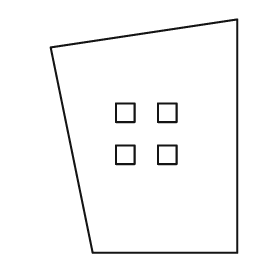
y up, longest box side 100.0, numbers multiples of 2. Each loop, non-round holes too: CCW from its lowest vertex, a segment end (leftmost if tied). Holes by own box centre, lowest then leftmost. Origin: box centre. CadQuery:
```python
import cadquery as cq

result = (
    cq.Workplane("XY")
    .moveTo(-22.0, -50.0)
    .lineTo(40.0, -50.0)
    .lineTo(40.0, 50.0)
    .lineTo(-40.0, 38.0)
    .close()
    .moveTo(-12.0, -12.0)
    .lineTo(-4.0, -12.0)
    .lineTo(-4.0, -4.0)
    .lineTo(-12.0, -4.0)
    .close()
    .moveTo(6.0, -12.0)
    .lineTo(14.0, -12.0)
    .lineTo(14.0, -4.0)
    .lineTo(6.0, -4.0)
    .close()
    .moveTo(-12.0, 6.0)
    .lineTo(-4.0, 6.0)
    .lineTo(-4.0, 14.0)
    .lineTo(-12.0, 14.0)
    .close()
    .moveTo(6.0, 6.0)
    .lineTo(14.0, 6.0)
    .lineTo(14.0, 14.0)
    .lineTo(6.0, 14.0)
    .close()
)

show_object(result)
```